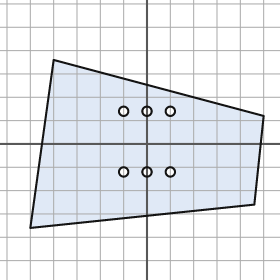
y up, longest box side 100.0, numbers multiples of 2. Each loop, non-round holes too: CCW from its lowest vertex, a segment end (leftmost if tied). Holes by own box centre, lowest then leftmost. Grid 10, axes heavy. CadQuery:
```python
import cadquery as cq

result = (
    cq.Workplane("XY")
    .moveTo(-50.0, -36.0)
    .lineTo(46.0, -26.0)
    .lineTo(50.0, 12.0)
    .lineTo(-40.0, 36.0)
    .close()
    .moveTo(-10.0, -12.0)
    .circle(2.0)
    .moveTo(0.0, -12.0)
    .circle(2.0)
    .moveTo(10.0, -12.0)
    .circle(2.0)
    .moveTo(-10.0, 14.0)
    .circle(2.0)
    .moveTo(0.0, 14.0)
    .circle(2.0)
    .moveTo(10.0, 14.0)
    .circle(2.0)
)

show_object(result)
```